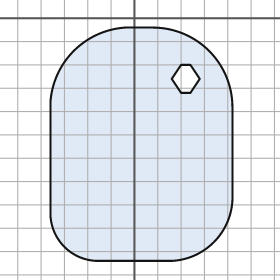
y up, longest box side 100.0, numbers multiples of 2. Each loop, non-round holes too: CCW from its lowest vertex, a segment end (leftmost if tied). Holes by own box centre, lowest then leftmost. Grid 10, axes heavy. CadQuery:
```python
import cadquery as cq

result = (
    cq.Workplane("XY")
    .moveTo(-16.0, -104.0)
    .lineTo(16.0, -104.0)
    .threePointArc((34.0, -96.0), (42.0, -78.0))
    .lineTo(42.0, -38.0)
    .threePointArc((32.0, -14.0), (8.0, -4.0))
    .lineTo(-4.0, -4.0)
    .threePointArc((-26.0, -14.0), (-36.0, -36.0))
    .lineTo(-36.0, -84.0)
    .threePointArc((-30.0, -98.0), (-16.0, -104.0))
    .close()
    .moveTo(20.0, -32.0)
    .lineTo(24.0, -32.0)
    .lineTo(28.0, -26.0)
    .lineTo(24.0, -20.0)
    .lineTo(20.0, -20.0)
    .lineTo(16.0, -26.0)
    .close()
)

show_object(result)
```